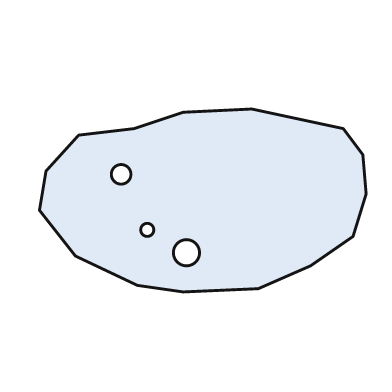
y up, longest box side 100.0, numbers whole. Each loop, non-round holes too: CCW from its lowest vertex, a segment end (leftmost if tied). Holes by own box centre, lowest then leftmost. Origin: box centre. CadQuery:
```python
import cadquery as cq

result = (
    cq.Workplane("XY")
    .moveTo(-6.0, -28.0)
    .lineTo(17.0, -27.0)
    .lineTo(33.0, -20.0)
    .lineTo(46.0, -11.0)
    .lineTo(50.0, 2.0)
    .lineTo(49.0, 14.0)
    .lineTo(43.0, 22.0)
    .lineTo(15.0, 28.0)
    .lineTo(-6.0, 27.0)
    .lineTo(-21.0, 22.0)
    .lineTo(-38.0, 20.0)
    .lineTo(-48.0, 9.0)
    .lineTo(-50.0, -3.0)
    .lineTo(-39.0, -17.0)
    .lineTo(-20.0, -26.0)
    .close()
    .moveTo(-5.0, -16.0)
    .circle(4.0)
    .moveTo(-17.0, -9.0)
    .circle(2.0)
    .moveTo(-25.0, 8.0)
    .circle(3.0)
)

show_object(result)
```